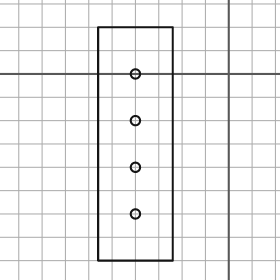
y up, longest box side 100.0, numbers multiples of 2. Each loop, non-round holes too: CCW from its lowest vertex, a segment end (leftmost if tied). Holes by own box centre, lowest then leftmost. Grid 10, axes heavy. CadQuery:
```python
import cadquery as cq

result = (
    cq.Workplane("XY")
    .moveTo(-56.0, -80.0)
    .lineTo(-24.0, -80.0)
    .lineTo(-24.0, 20.0)
    .lineTo(-56.0, 20.0)
    .close()
    .moveTo(-40.0, -60.0)
    .circle(2.0)
    .moveTo(-40.0, -40.0)
    .circle(2.0)
    .moveTo(-40.0, -20.0)
    .circle(2.0)
    .moveTo(-40.0, 0.0)
    .circle(2.0)
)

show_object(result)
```